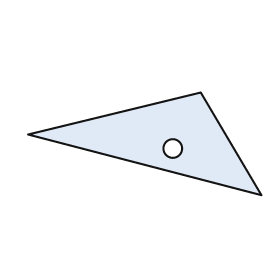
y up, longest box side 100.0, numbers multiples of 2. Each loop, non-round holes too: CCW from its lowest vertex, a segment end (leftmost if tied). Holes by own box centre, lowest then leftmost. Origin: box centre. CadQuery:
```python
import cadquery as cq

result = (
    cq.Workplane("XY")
    .moveTo(50.0, -22.0)
    .lineTo(24.0, 22.0)
    .lineTo(-50.0, 4.0)
    .close()
    .moveTo(12.0, -2.0)
    .circle(4.0)
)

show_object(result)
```